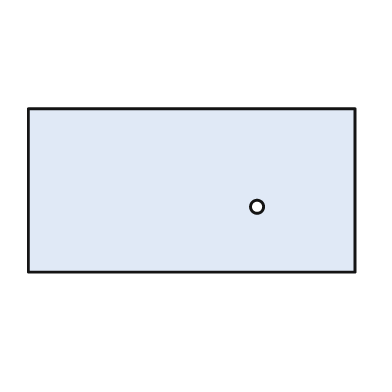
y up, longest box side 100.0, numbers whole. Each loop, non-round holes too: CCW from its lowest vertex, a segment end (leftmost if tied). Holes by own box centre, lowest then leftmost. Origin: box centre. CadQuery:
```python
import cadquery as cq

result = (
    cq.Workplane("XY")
    .moveTo(-50.0, -25.0)
    .lineTo(50.0, -25.0)
    .lineTo(50.0, 25.0)
    .lineTo(-50.0, 25.0)
    .close()
    .moveTo(20.0, -5.0)
    .circle(2.0)
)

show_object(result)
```